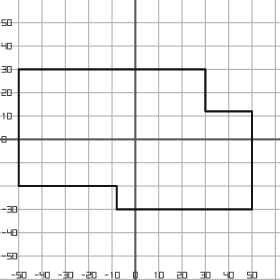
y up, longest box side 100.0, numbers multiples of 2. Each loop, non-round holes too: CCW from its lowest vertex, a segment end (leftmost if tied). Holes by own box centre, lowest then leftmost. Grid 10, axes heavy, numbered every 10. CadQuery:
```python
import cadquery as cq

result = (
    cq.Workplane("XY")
    .moveTo(-8.0, -30.0)
    .lineTo(50.0, -30.0)
    .lineTo(50.0, 12.0)
    .lineTo(30.0, 12.0)
    .lineTo(30.0, 30.0)
    .lineTo(-50.0, 30.0)
    .lineTo(-50.0, -20.0)
    .lineTo(-8.0, -20.0)
    .close()
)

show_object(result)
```